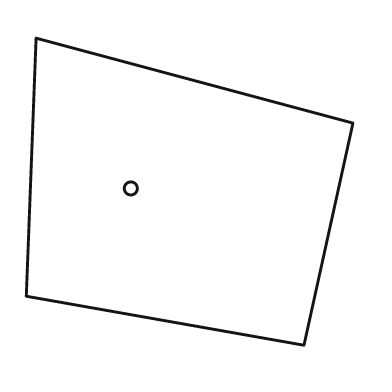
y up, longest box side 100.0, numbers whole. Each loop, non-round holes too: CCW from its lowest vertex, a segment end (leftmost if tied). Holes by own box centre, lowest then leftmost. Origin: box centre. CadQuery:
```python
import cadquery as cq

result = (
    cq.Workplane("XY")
    .moveTo(35.0, -47.0)
    .lineTo(50.0, 21.0)
    .lineTo(-47.0, 47.0)
    .lineTo(-50.0, -32.0)
    .close()
    .moveTo(-18.0, 1.0)
    .circle(2.0)
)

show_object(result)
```